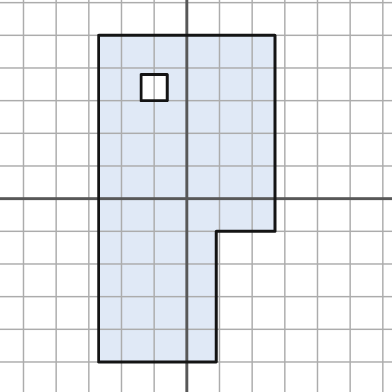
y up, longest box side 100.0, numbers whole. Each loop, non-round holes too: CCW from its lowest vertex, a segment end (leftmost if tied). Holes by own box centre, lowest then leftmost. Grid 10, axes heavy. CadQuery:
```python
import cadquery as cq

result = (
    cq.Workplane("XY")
    .moveTo(-27.0, -50.0)
    .lineTo(9.0, -50.0)
    .lineTo(9.0, -10.0)
    .lineTo(27.0, -10.0)
    .lineTo(27.0, 50.0)
    .lineTo(-27.0, 50.0)
    .close()
    .moveTo(-14.0, 30.0)
    .lineTo(-6.0, 30.0)
    .lineTo(-6.0, 38.0)
    .lineTo(-14.0, 38.0)
    .close()
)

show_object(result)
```